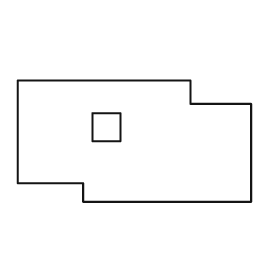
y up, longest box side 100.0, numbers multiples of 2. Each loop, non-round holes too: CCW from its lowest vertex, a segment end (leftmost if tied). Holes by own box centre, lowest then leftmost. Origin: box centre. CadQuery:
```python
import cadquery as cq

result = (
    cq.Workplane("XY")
    .moveTo(-22.0, -26.0)
    .lineTo(50.0, -26.0)
    .lineTo(50.0, 16.0)
    .lineTo(24.0, 16.0)
    .lineTo(24.0, 26.0)
    .lineTo(-50.0, 26.0)
    .lineTo(-50.0, -18.0)
    .lineTo(-22.0, -18.0)
    .close()
    .moveTo(-18.0, 0.0)
    .lineTo(-6.0, 0.0)
    .lineTo(-6.0, 12.0)
    .lineTo(-18.0, 12.0)
    .close()
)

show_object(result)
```